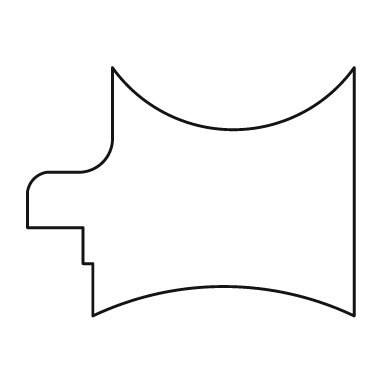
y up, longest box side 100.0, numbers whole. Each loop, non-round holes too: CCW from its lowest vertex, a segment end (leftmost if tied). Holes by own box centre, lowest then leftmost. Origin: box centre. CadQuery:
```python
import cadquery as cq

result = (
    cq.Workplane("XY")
    .moveTo(-30.0, -38.0)
    .threePointArc((10.0, -29.0), (50.0, -38.0))
    .lineTo(50.0, 38.0)
    .threePointArc((13.0, 19.0), (-24.0, 38.0))
    .lineTo(-24.0, 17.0)
    .threePointArc((-27.0, 9.0), (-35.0, 6.0))
    .lineTo(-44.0, 6.0)
    .threePointArc((-48.0, 4.0), (-50.0, 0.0))
    .lineTo(-50.0, -11.0)
    .lineTo(-33.0, -11.0)
    .lineTo(-33.0, -22.0)
    .lineTo(-30.0, -22.0)
    .close()
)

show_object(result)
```